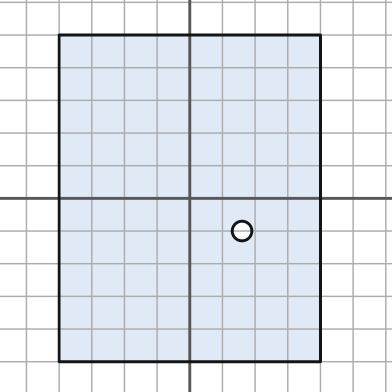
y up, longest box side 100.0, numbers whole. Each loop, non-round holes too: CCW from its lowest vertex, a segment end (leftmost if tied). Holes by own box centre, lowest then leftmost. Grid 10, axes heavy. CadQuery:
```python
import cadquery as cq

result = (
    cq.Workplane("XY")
    .moveTo(-40.0, -50.0)
    .lineTo(40.0, -50.0)
    .lineTo(40.0, 50.0)
    .lineTo(-40.0, 50.0)
    .close()
    .moveTo(16.0, -10.0)
    .circle(3.0)
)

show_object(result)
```